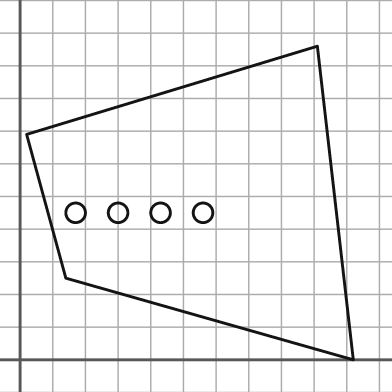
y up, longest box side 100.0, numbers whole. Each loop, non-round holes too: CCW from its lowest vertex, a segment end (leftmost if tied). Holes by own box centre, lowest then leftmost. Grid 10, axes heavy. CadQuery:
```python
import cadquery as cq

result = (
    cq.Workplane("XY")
    .moveTo(102.0, 0.0)
    .lineTo(91.0, 96.0)
    .lineTo(2.0, 69.0)
    .lineTo(14.0, 25.0)
    .close()
    .moveTo(17.0, 45.0)
    .circle(3.0)
    .moveTo(30.0, 45.0)
    .circle(3.0)
    .moveTo(43.0, 45.0)
    .circle(3.0)
    .moveTo(56.0, 45.0)
    .circle(3.0)
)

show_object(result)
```